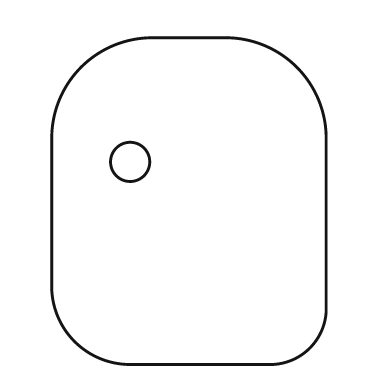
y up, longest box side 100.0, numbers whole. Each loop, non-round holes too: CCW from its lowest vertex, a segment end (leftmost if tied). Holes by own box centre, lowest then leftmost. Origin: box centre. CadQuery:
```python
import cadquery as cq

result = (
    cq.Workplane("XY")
    .moveTo(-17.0, -50.0)
    .lineTo(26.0, -50.0)
    .threePointArc((37.0, -45.0), (42.0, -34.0))
    .lineTo(42.0, 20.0)
    .threePointArc((33.0, 41.0), (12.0, 50.0))
    .lineTo(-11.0, 50.0)
    .threePointArc((-33.0, 41.0), (-42.0, 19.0))
    .lineTo(-42.0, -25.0)
    .threePointArc((-35.0, -43.0), (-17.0, -50.0))
    .close()
    .moveTo(-18.0, 12.0)
    .circle(6.0)
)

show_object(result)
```